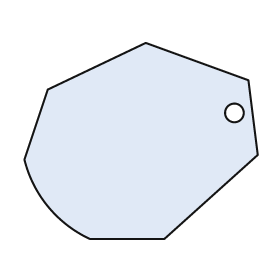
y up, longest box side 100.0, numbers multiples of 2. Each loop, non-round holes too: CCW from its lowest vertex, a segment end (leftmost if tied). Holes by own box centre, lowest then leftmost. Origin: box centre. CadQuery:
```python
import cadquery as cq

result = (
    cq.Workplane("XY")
    .moveTo(-22.0, -42.0)
    .lineTo(10.0, -42.0)
    .lineTo(50.0, -6.0)
    .lineTo(46.0, 26.0)
    .lineTo(2.0, 42.0)
    .lineTo(-40.0, 22.0)
    .lineTo(-50.0, -8.0)
    .threePointArc((-40.0, -28.0), (-22.0, -42.0))
    .close()
    .moveTo(40.0, 12.0)
    .circle(4.0)
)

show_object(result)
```